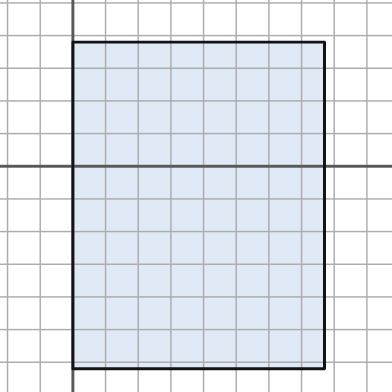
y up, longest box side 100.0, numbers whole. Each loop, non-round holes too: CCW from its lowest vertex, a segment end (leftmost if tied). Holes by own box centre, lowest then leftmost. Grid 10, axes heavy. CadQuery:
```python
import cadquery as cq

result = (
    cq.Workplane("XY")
    .moveTo(0.0, -62.0)
    .lineTo(77.0, -62.0)
    .lineTo(77.0, 38.0)
    .lineTo(0.0, 38.0)
    .close()
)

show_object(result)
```